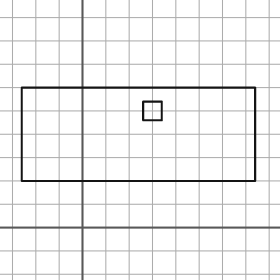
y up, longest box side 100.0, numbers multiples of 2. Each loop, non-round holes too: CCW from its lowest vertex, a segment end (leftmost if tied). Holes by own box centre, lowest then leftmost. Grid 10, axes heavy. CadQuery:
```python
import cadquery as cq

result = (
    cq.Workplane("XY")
    .moveTo(-26.0, 20.0)
    .lineTo(74.0, 20.0)
    .lineTo(74.0, 60.0)
    .lineTo(-26.0, 60.0)
    .close()
    .moveTo(26.0, 46.0)
    .lineTo(34.0, 46.0)
    .lineTo(34.0, 54.0)
    .lineTo(26.0, 54.0)
    .close()
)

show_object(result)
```